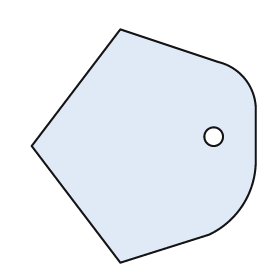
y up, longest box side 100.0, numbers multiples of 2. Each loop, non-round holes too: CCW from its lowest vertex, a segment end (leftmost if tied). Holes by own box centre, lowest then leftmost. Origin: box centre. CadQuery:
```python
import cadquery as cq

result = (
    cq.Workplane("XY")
    .moveTo(-10.0, -50.0)
    .lineTo(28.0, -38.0)
    .threePointArc((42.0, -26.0), (48.0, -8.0))
    .lineTo(48.0, 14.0)
    .threePointArc((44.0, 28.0), (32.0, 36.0))
    .lineTo(-10.0, 50.0)
    .lineTo(-48.0, 0.0)
    .close()
    .moveTo(30.0, 4.0)
    .circle(4.0)
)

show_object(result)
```